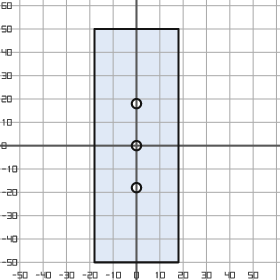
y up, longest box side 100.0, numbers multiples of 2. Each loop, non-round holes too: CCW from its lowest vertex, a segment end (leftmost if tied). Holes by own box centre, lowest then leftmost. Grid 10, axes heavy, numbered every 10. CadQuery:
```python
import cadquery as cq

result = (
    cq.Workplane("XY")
    .moveTo(-18.0, -50.0)
    .lineTo(18.0, -50.0)
    .lineTo(18.0, 50.0)
    .lineTo(-18.0, 50.0)
    .close()
    .moveTo(0.0, -18.0)
    .circle(2.0)
    .moveTo(0.0, 0.0)
    .circle(2.0)
    .moveTo(0.0, 18.0)
    .circle(2.0)
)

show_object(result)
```